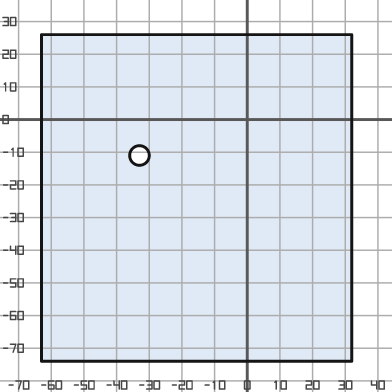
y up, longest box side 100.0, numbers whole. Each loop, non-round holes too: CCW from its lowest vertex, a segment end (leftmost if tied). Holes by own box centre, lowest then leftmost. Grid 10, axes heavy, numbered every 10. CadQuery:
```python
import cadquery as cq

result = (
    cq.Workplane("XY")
    .moveTo(-63.0, -74.0)
    .lineTo(32.0, -74.0)
    .lineTo(32.0, 26.0)
    .lineTo(-63.0, 26.0)
    .close()
    .moveTo(-33.0, -11.0)
    .circle(3.0)
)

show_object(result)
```